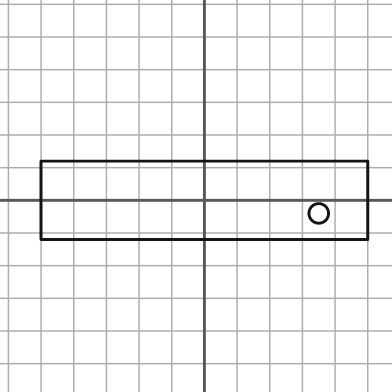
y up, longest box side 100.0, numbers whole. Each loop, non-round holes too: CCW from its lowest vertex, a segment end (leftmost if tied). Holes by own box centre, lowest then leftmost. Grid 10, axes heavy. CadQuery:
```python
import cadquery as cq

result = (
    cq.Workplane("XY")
    .moveTo(-50.0, -12.0)
    .lineTo(50.0, -12.0)
    .lineTo(50.0, 12.0)
    .lineTo(-50.0, 12.0)
    .close()
    .moveTo(35.0, -4.0)
    .circle(3.0)
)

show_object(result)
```